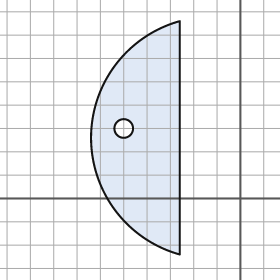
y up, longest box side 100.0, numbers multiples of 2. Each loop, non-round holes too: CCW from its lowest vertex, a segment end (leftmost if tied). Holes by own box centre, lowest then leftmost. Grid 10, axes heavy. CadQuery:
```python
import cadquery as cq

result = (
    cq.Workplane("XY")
    .moveTo(-26.0, -24.0)
    .lineTo(-26.0, 76.0)
    .threePointArc((-64.0, 26.0), (-26.0, -24.0))
    .close()
    .moveTo(-50.0, 30.0)
    .circle(4.0)
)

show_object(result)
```